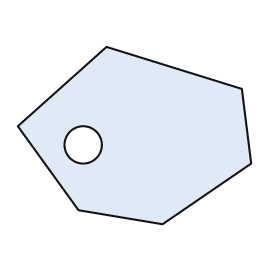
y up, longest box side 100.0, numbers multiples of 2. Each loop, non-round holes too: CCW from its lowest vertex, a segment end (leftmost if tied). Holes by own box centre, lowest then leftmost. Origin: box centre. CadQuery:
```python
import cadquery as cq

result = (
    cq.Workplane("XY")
    .moveTo(12.0, -38.0)
    .lineTo(50.0, -12.0)
    .lineTo(46.0, 20.0)
    .lineTo(-12.0, 38.0)
    .lineTo(-50.0, 4.0)
    .lineTo(-24.0, -32.0)
    .close()
    .moveTo(-22.0, -4.0)
    .circle(8.0)
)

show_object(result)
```